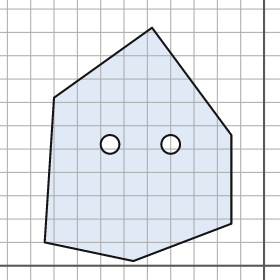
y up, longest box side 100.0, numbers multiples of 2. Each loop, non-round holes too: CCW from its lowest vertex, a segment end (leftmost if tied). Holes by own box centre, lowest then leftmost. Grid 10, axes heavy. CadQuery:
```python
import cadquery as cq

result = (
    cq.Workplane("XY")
    .moveTo(-56.0, 2.0)
    .lineTo(-14.0, 18.0)
    .lineTo(-14.0, 56.0)
    .lineTo(-48.0, 102.0)
    .lineTo(-90.0, 72.0)
    .lineTo(-94.0, 10.0)
    .close()
    .moveTo(-66.0, 52.0)
    .circle(4.0)
    .moveTo(-40.0, 52.0)
    .circle(4.0)
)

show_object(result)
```